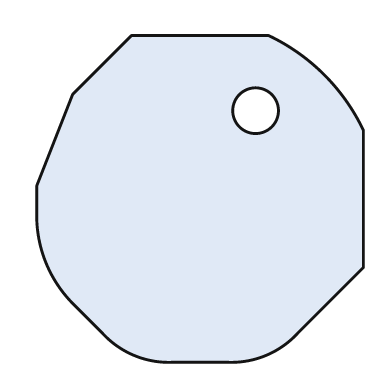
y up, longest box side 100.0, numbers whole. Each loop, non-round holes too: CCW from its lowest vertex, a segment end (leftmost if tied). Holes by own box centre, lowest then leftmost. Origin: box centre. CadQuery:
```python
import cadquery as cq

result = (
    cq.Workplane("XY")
    .moveTo(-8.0, -50.0)
    .lineTo(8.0, -50.0)
    .threePointArc((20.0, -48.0), (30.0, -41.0))
    .lineTo(50.0, -21.0)
    .lineTo(50.0, 21.0)
    .threePointArc((38.0, 38.0), (21.0, 50.0))
    .lineTo(-21.0, 50.0)
    .lineTo(-39.0, 32.0)
    .lineTo(-50.0, 4.0)
    .lineTo(-50.0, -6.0)
    .threePointArc((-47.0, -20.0), (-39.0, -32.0))
    .lineTo(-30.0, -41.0)
    .threePointArc((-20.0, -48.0), (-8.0, -50.0))
    .close()
    .moveTo(17.0, 27.0)
    .circle(7.0)
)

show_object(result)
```